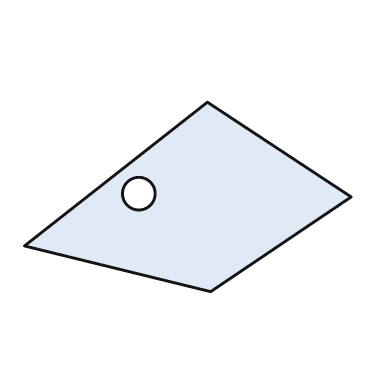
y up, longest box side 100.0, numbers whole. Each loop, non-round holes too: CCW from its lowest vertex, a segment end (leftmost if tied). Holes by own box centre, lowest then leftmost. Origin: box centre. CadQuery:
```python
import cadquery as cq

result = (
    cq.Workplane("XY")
    .moveTo(7.0, -29.0)
    .lineTo(50.0, 0.0)
    .lineTo(6.0, 29.0)
    .lineTo(-50.0, -15.0)
    .close()
    .moveTo(-15.0, 1.0)
    .circle(5.0)
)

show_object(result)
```